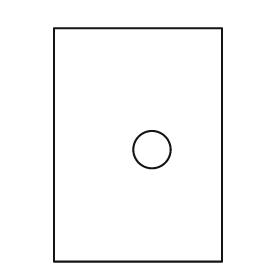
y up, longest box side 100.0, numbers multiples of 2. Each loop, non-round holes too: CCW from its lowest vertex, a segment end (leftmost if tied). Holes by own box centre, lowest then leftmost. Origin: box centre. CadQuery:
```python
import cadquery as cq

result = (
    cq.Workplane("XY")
    .moveTo(-36.0, -50.0)
    .lineTo(36.0, -50.0)
    .lineTo(36.0, 50.0)
    .lineTo(-36.0, 50.0)
    .close()
    .moveTo(6.0, -2.0)
    .circle(8.0)
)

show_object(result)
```